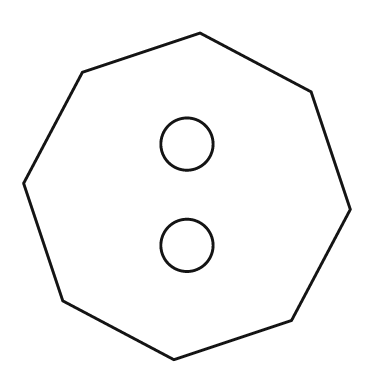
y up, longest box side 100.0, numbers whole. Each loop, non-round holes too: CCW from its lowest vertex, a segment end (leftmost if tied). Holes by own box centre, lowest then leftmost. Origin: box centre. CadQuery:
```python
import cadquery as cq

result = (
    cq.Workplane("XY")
    .moveTo(-4.0, -50.0)
    .lineTo(32.0, -38.0)
    .lineTo(50.0, -4.0)
    .lineTo(38.0, 32.0)
    .lineTo(4.0, 50.0)
    .lineTo(-32.0, 38.0)
    .lineTo(-50.0, 4.0)
    .lineTo(-38.0, -32.0)
    .close()
    .moveTo(0.0, -15.0)
    .circle(8.0)
    .moveTo(0.0, 16.0)
    .circle(8.0)
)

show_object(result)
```